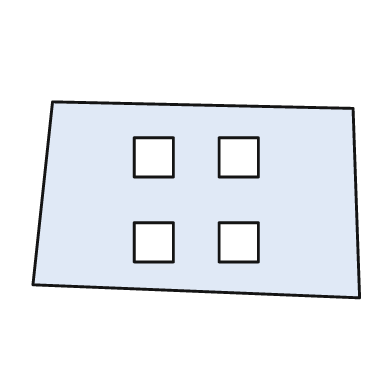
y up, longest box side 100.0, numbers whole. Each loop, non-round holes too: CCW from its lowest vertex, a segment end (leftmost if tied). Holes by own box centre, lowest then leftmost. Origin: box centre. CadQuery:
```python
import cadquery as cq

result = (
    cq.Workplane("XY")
    .moveTo(50.0, -30.0)
    .lineTo(48.0, 28.0)
    .lineTo(-44.0, 30.0)
    .lineTo(-50.0, -26.0)
    .close()
    .moveTo(-19.0, -19.0)
    .lineTo(-7.0, -19.0)
    .lineTo(-7.0, -7.0)
    .lineTo(-19.0, -7.0)
    .close()
    .moveTo(7.0, -19.0)
    .lineTo(19.0, -19.0)
    .lineTo(19.0, -7.0)
    .lineTo(7.0, -7.0)
    .close()
    .moveTo(-19.0, 7.0)
    .lineTo(-7.0, 7.0)
    .lineTo(-7.0, 19.0)
    .lineTo(-19.0, 19.0)
    .close()
    .moveTo(7.0, 7.0)
    .lineTo(19.0, 7.0)
    .lineTo(19.0, 19.0)
    .lineTo(7.0, 19.0)
    .close()
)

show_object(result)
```